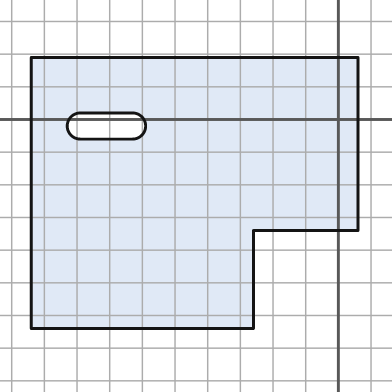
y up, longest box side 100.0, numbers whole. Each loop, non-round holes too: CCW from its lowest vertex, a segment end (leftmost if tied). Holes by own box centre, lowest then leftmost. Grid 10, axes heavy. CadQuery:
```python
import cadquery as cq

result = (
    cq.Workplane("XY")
    .moveTo(-94.0, -64.0)
    .lineTo(-26.0, -64.0)
    .lineTo(-26.0, -34.0)
    .lineTo(6.0, -34.0)
    .lineTo(6.0, 19.0)
    .lineTo(-94.0, 19.0)
    .close()
    .moveTo(-79.0, -6.0)
    .lineTo(-63.0, -6.0)
    .threePointArc((-59.0, -2.0), (-63.0, 2.0))
    .lineTo(-79.0, 2.0)
    .threePointArc((-83.0, -2.0), (-79.0, -6.0))
    .close()
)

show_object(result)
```